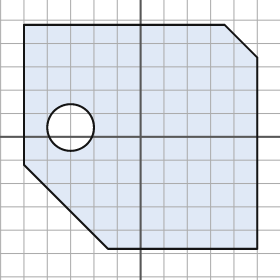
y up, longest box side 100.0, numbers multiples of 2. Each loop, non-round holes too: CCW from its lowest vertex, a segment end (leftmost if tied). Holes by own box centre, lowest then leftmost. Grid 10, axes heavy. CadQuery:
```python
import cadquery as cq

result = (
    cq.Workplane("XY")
    .moveTo(-14.0, -48.0)
    .lineTo(50.0, -48.0)
    .lineTo(50.0, 34.0)
    .lineTo(36.0, 48.0)
    .lineTo(-50.0, 48.0)
    .lineTo(-50.0, -12.0)
    .close()
    .moveTo(-30.0, 4.0)
    .circle(10.0)
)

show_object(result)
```